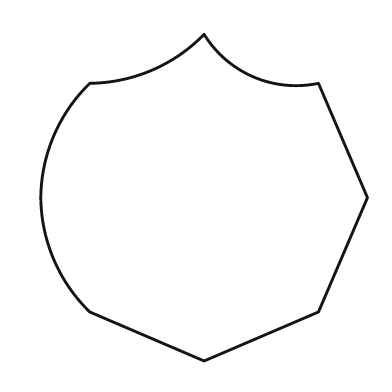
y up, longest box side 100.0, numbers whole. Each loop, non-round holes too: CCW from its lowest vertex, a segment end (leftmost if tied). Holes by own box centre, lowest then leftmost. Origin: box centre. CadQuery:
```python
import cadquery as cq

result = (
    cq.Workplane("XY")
    .moveTo(0.0, -50.0)
    .lineTo(35.0, -35.0)
    .lineTo(50.0, 0.0)
    .lineTo(35.0, 35.0)
    .threePointArc((15.0, 37.0), (0.0, 50.0))
    .threePointArc((-16.0, 39.0), (-35.0, 35.0))
    .threePointArc((-46.0, 19.0), (-50.0, 0.0))
    .threePointArc((-46.0, -19.0), (-35.0, -35.0))
    .close()
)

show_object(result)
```